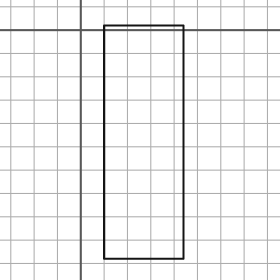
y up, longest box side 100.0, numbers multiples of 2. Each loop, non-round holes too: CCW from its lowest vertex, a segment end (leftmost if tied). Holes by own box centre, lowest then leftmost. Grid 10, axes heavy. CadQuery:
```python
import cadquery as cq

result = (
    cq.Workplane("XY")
    .moveTo(10.0, -98.0)
    .lineTo(44.0, -98.0)
    .lineTo(44.0, 2.0)
    .lineTo(10.0, 2.0)
    .close()
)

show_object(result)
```